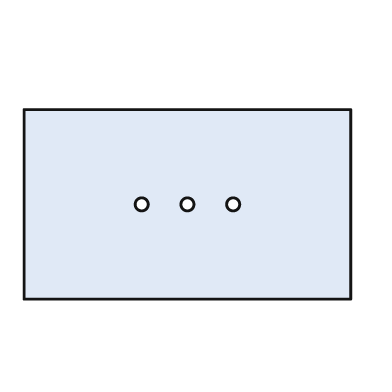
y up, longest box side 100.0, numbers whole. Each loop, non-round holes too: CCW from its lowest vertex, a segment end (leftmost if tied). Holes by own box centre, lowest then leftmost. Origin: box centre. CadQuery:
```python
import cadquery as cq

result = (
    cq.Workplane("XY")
    .moveTo(-50.0, -29.0)
    .lineTo(50.0, -29.0)
    .lineTo(50.0, 29.0)
    .lineTo(-50.0, 29.0)
    .close()
    .moveTo(-14.0, 0.0)
    .circle(2.0)
    .moveTo(0.0, 0.0)
    .circle(2.0)
    .moveTo(14.0, 0.0)
    .circle(2.0)
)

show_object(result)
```